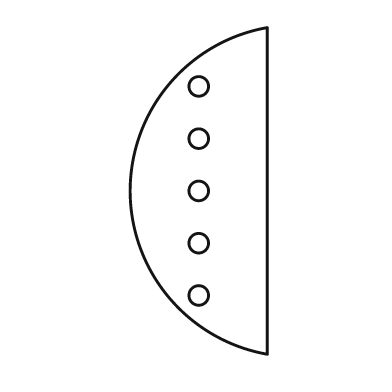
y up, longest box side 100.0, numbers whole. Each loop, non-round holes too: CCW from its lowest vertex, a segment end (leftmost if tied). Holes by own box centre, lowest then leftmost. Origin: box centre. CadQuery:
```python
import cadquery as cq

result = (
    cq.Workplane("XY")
    .moveTo(21.0, -50.0)
    .lineTo(21.0, 50.0)
    .threePointArc((-21.0, 0.0), (21.0, -50.0))
    .close()
    .moveTo(0.0, -32.0)
    .circle(3.0)
    .moveTo(0.0, -16.0)
    .circle(3.0)
    .moveTo(0.0, 0.0)
    .circle(3.0)
    .moveTo(0.0, 16.0)
    .circle(3.0)
    .moveTo(0.0, 32.0)
    .circle(3.0)
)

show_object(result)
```